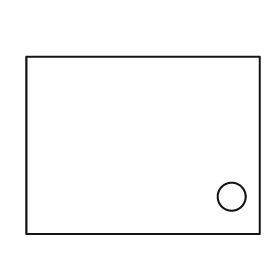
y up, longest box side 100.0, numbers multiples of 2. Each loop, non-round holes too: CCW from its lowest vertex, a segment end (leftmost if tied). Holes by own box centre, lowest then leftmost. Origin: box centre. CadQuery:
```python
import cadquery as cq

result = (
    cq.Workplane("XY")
    .moveTo(-50.0, -38.0)
    .lineTo(50.0, -38.0)
    .lineTo(50.0, 38.0)
    .lineTo(-50.0, 38.0)
    .close()
    .moveTo(38.0, -22.0)
    .circle(6.0)
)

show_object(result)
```